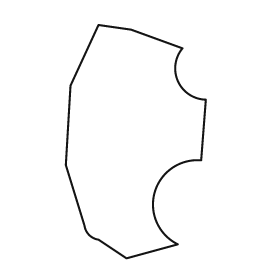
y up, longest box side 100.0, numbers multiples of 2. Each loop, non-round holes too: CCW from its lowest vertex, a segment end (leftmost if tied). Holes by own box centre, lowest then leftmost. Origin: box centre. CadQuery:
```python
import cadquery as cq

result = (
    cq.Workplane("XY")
    .moveTo(-4.0, -50.0)
    .lineTo(18.0, -44.0)
    .threePointArc((8.0, -22.0), (28.0, -8.0))
    .lineTo(30.0, 18.0)
    .threePointArc((18.0, 26.0), (20.0, 40.0))
    .lineTo(-2.0, 48.0)
    .lineTo(-16.0, 50.0)
    .lineTo(-28.0, 24.0)
    .lineTo(-30.0, -10.0)
    .lineTo(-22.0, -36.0)
    .threePointArc((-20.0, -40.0), (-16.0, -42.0))
    .close()
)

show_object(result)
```